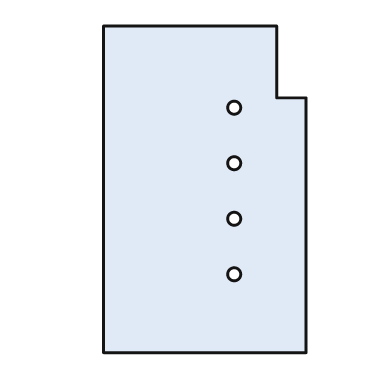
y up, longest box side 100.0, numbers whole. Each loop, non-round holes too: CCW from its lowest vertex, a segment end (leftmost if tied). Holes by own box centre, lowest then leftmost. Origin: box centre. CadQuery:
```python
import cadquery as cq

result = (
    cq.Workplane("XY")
    .moveTo(-31.0, -50.0)
    .lineTo(31.0, -50.0)
    .lineTo(31.0, 28.0)
    .lineTo(22.0, 28.0)
    .lineTo(22.0, 50.0)
    .lineTo(-31.0, 50.0)
    .close()
    .moveTo(9.0, -26.0)
    .circle(2.0)
    .moveTo(9.0, -9.0)
    .circle(2.0)
    .moveTo(9.0, 8.0)
    .circle(2.0)
    .moveTo(9.0, 25.0)
    .circle(2.0)
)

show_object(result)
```